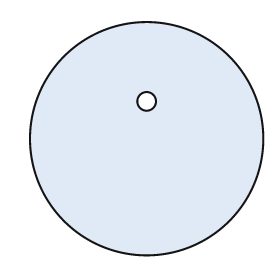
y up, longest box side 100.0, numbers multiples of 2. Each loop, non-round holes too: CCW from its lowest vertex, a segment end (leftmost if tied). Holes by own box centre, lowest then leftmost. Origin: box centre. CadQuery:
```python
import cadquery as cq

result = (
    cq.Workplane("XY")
    .moveTo(0.0, 0.0)
    .circle(50.0)
    .moveTo(0.0, 16.0)
    .circle(4.0)
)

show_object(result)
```